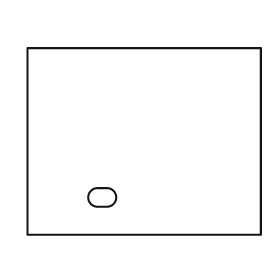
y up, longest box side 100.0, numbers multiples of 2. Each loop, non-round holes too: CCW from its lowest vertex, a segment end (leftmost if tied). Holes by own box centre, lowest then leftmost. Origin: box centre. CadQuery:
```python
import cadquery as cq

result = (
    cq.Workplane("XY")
    .moveTo(-50.0, -40.0)
    .lineTo(50.0, -40.0)
    .lineTo(50.0, 40.0)
    .lineTo(-50.0, 40.0)
    .close()
    .moveTo(-20.0, -28.0)
    .lineTo(-16.0, -28.0)
    .threePointArc((-12.0, -24.0), (-16.0, -20.0))
    .lineTo(-20.0, -20.0)
    .threePointArc((-24.0, -24.0), (-20.0, -28.0))
    .close()
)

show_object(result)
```